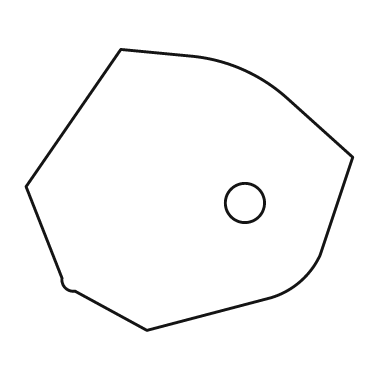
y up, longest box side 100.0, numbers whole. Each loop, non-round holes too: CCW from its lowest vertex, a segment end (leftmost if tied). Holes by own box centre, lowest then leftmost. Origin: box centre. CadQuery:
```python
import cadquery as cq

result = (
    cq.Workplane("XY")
    .moveTo(-13.0, -43.0)
    .lineTo(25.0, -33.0)
    .threePointArc((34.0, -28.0), (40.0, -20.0))
    .lineTo(50.0, 10.0)
    .lineTo(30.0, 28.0)
    .threePointArc((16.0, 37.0), (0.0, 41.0))
    .lineTo(-21.0, 43.0)
    .lineTo(-50.0, 1.0)
    .lineTo(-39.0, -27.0)
    .threePointArc((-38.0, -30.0), (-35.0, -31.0))
    .close()
    .moveTo(17.0, -4.0)
    .circle(6.0)
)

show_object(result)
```